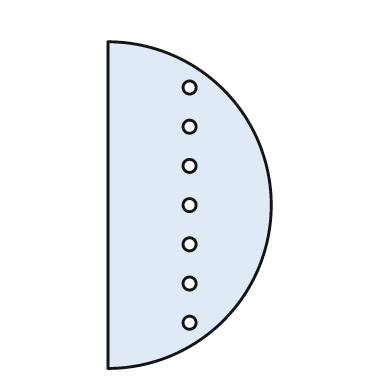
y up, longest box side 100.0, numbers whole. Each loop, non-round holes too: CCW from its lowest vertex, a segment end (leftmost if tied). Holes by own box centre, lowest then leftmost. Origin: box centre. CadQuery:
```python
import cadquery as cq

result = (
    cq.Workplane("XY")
    .moveTo(-25.0, -50.0)
    .threePointArc((25.0, 0.0), (-25.0, 50.0))
    .close()
    .moveTo(0.0, -36.0)
    .circle(2.0)
    .moveTo(0.0, -24.0)
    .circle(2.0)
    .moveTo(0.0, -12.0)
    .circle(2.0)
    .moveTo(0.0, 0.0)
    .circle(2.0)
    .moveTo(0.0, 12.0)
    .circle(2.0)
    .moveTo(0.0, 24.0)
    .circle(2.0)
    .moveTo(0.0, 36.0)
    .circle(2.0)
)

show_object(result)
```